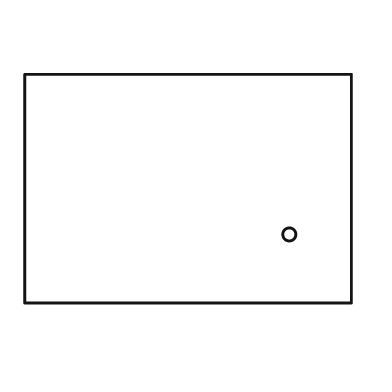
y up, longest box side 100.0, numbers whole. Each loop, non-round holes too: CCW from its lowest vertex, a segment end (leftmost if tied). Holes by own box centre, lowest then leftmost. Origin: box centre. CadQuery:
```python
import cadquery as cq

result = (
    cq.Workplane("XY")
    .moveTo(-50.0, -35.0)
    .lineTo(50.0, -35.0)
    .lineTo(50.0, 35.0)
    .lineTo(-50.0, 35.0)
    .close()
    .moveTo(31.0, -14.0)
    .circle(2.0)
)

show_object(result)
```